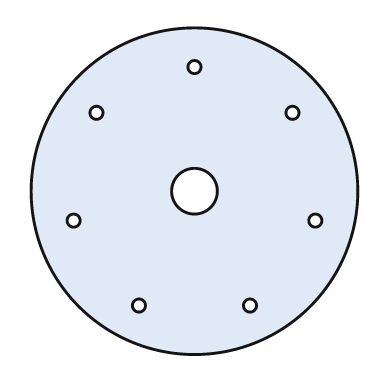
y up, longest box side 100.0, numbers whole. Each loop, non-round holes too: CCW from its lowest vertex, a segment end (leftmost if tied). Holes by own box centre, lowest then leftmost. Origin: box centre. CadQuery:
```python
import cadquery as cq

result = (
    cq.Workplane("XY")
    .moveTo(0.0, 0.0)
    .circle(50.0)
    .moveTo(-17.0, -35.0)
    .circle(2.0)
    .moveTo(17.0, -35.0)
    .circle(2.0)
    .moveTo(-37.0, -9.0)
    .circle(2.0)
    .moveTo(37.0, -9.0)
    .circle(2.0)
    .moveTo(0.0, 0.0)
    .circle(7.0)
    .moveTo(-30.0, 24.0)
    .circle(2.0)
    .moveTo(30.0, 24.0)
    .circle(2.0)
    .moveTo(0.0, 38.0)
    .circle(2.0)
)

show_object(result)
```